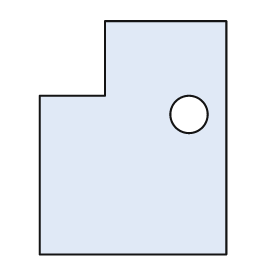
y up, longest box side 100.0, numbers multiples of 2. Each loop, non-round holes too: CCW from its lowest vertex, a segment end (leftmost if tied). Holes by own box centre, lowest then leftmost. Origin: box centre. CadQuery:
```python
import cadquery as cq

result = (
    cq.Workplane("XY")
    .moveTo(-40.0, -50.0)
    .lineTo(40.0, -50.0)
    .lineTo(40.0, 50.0)
    .lineTo(-12.0, 50.0)
    .lineTo(-12.0, 18.0)
    .lineTo(-40.0, 18.0)
    .close()
    .moveTo(24.0, 10.0)
    .circle(8.0)
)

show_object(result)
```